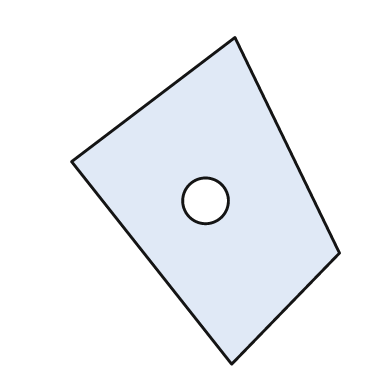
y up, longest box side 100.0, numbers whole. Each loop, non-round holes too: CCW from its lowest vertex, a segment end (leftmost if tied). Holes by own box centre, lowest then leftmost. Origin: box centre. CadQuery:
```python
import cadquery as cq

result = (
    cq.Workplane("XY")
    .moveTo(8.0, -50.0)
    .lineTo(41.0, -16.0)
    .lineTo(9.0, 50.0)
    .lineTo(-41.0, 12.0)
    .close()
    .moveTo(0.0, 0.0)
    .circle(7.0)
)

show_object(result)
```